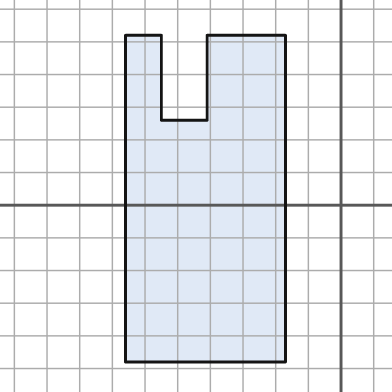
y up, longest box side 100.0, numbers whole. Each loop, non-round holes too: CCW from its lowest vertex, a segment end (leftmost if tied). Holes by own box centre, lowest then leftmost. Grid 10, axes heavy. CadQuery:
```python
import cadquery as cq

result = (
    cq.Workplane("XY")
    .moveTo(-66.0, -48.0)
    .lineTo(-17.0, -48.0)
    .lineTo(-17.0, 52.0)
    .lineTo(-41.0, 52.0)
    .lineTo(-41.0, 26.0)
    .lineTo(-55.0, 26.0)
    .lineTo(-55.0, 52.0)
    .lineTo(-66.0, 52.0)
    .close()
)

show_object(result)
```